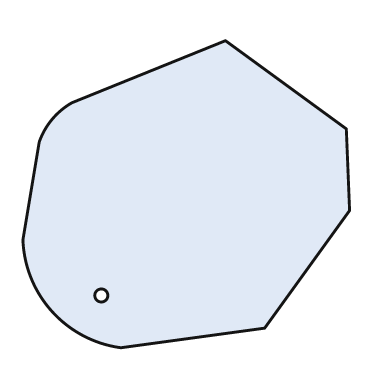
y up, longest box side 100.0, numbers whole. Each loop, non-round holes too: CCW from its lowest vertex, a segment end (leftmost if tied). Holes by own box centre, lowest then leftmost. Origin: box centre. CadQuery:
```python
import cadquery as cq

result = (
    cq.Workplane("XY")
    .moveTo(-20.0, -47.0)
    .lineTo(24.0, -41.0)
    .lineTo(50.0, -5.0)
    .lineTo(49.0, 20.0)
    .lineTo(12.0, 47.0)
    .lineTo(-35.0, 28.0)
    .threePointArc((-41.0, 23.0), (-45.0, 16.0))
    .lineTo(-50.0, -14.0)
    .threePointArc((-41.0, -36.0), (-20.0, -47.0))
    .close()
    .moveTo(-26.0, -31.0)
    .circle(2.0)
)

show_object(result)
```